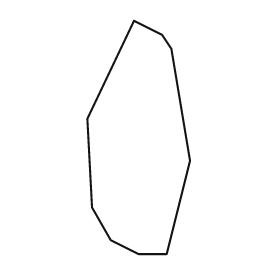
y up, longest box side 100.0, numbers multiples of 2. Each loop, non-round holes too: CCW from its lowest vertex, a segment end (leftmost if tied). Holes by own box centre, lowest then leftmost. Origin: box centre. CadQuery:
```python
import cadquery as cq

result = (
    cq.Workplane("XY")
    .moveTo(0.0, -50.0)
    .lineTo(12.0, -50.0)
    .lineTo(22.0, -10.0)
    .lineTo(14.0, 38.0)
    .lineTo(10.0, 44.0)
    .lineTo(-2.0, 50.0)
    .lineTo(-22.0, 8.0)
    .lineTo(-20.0, -30.0)
    .lineTo(-12.0, -44.0)
    .close()
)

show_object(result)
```